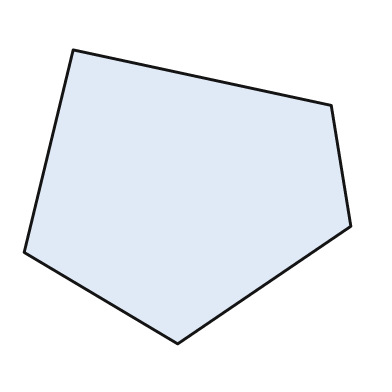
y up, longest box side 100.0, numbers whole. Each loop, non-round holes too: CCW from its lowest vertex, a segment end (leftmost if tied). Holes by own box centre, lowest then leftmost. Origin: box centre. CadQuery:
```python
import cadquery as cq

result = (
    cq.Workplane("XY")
    .moveTo(-3.0, -45.0)
    .lineTo(50.0, -9.0)
    .lineTo(44.0, 28.0)
    .lineTo(-35.0, 45.0)
    .lineTo(-50.0, -17.0)
    .close()
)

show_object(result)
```